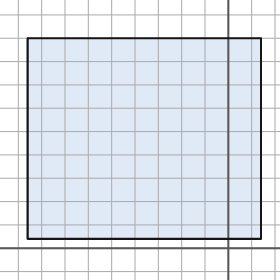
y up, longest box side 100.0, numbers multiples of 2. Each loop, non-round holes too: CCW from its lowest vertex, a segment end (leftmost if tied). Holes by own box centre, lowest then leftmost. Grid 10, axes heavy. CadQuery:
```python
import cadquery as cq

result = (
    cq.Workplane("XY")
    .moveTo(-86.0, 4.0)
    .lineTo(14.0, 4.0)
    .lineTo(14.0, 90.0)
    .lineTo(-86.0, 90.0)
    .close()
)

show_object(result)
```